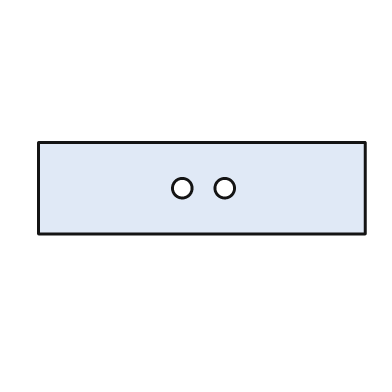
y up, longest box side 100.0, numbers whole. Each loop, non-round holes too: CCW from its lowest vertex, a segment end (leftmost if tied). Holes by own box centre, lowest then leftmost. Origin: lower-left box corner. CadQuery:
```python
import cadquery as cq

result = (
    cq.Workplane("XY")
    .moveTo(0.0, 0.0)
    .lineTo(100.0, 0.0)
    .lineTo(100.0, 28.0)
    .lineTo(0.0, 28.0)
    .close()
    .moveTo(44.0, 14.0)
    .circle(3.0)
    .moveTo(57.0, 14.0)
    .circle(3.0)
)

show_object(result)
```